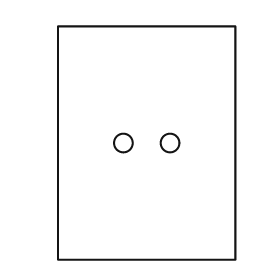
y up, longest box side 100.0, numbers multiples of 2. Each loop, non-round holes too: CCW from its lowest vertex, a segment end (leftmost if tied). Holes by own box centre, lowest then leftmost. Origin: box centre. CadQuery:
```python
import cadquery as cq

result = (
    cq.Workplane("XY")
    .moveTo(-38.0, -50.0)
    .lineTo(38.0, -50.0)
    .lineTo(38.0, 50.0)
    .lineTo(-38.0, 50.0)
    .close()
    .moveTo(-10.0, 0.0)
    .circle(4.0)
    .moveTo(10.0, 0.0)
    .circle(4.0)
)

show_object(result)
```